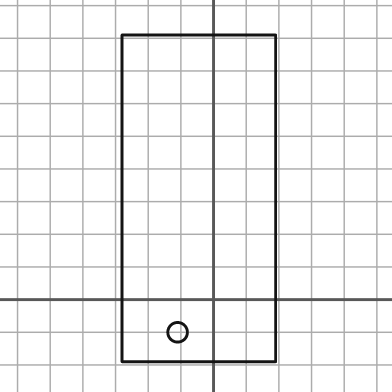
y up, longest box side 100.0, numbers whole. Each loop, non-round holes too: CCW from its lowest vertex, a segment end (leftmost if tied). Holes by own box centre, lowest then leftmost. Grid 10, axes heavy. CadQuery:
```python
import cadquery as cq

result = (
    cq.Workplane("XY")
    .moveTo(-28.0, -19.0)
    .lineTo(19.0, -19.0)
    .lineTo(19.0, 81.0)
    .lineTo(-28.0, 81.0)
    .close()
    .moveTo(-11.0, -10.0)
    .circle(3.0)
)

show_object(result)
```